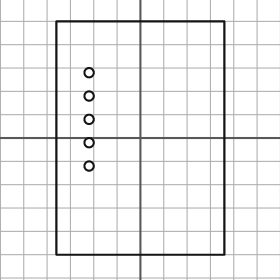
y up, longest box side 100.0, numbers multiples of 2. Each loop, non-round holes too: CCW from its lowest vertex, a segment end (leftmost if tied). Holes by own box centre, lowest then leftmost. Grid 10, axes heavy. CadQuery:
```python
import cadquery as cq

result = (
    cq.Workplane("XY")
    .moveTo(-36.0, -50.0)
    .lineTo(36.0, -50.0)
    .lineTo(36.0, 50.0)
    .lineTo(-36.0, 50.0)
    .close()
    .moveTo(-22.0, -12.0)
    .circle(2.0)
    .moveTo(-22.0, -2.0)
    .circle(2.0)
    .moveTo(-22.0, 8.0)
    .circle(2.0)
    .moveTo(-22.0, 18.0)
    .circle(2.0)
    .moveTo(-22.0, 28.0)
    .circle(2.0)
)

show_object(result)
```